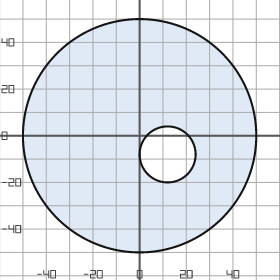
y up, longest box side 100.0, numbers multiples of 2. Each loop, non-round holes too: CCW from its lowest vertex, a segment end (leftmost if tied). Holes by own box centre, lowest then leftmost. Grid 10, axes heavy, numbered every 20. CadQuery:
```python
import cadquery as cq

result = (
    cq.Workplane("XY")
    .moveTo(0.0, 0.0)
    .circle(50.0)
    .moveTo(12.0, -8.0)
    .circle(12.0)
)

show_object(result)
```